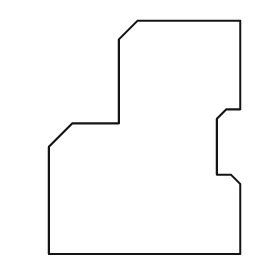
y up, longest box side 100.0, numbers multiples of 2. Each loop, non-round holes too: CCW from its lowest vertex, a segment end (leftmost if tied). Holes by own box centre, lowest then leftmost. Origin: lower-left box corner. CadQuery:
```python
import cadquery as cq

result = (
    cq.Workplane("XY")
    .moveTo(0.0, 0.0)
    .lineTo(82.0, 0.0)
    .lineTo(82.0, 30.0)
    .lineTo(78.0, 34.0)
    .lineTo(72.0, 34.0)
    .lineTo(72.0, 58.0)
    .lineTo(76.0, 62.0)
    .lineTo(82.0, 62.0)
    .lineTo(82.0, 100.0)
    .lineTo(38.0, 100.0)
    .lineTo(30.0, 92.0)
    .lineTo(30.0, 56.0)
    .lineTo(10.0, 56.0)
    .lineTo(0.0, 46.0)
    .close()
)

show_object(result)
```